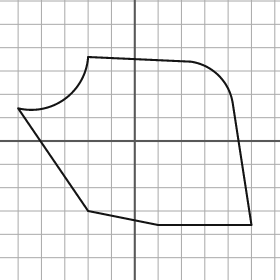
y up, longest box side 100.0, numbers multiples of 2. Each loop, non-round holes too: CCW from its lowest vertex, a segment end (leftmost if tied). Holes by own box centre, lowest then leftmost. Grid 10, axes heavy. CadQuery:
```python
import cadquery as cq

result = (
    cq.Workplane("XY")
    .moveTo(10.0, -36.0)
    .lineTo(50.0, -36.0)
    .lineTo(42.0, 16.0)
    .threePointArc((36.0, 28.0), (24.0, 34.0))
    .lineTo(-20.0, 36.0)
    .threePointArc((-30.0, 18.0), (-50.0, 14.0))
    .lineTo(-20.0, -30.0)
    .close()
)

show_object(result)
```